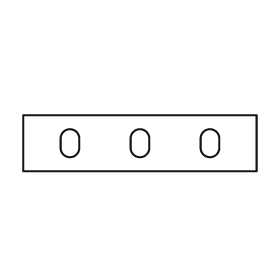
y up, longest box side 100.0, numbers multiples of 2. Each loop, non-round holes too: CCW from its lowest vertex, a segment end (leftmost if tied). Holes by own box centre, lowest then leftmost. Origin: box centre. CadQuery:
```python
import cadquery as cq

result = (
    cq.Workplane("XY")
    .moveTo(-50.0, -12.0)
    .lineTo(50.0, -12.0)
    .lineTo(50.0, 12.0)
    .lineTo(-50.0, 12.0)
    .close()
    .moveTo(-34.0, -2.0)
    .threePointArc((-30.0, -6.0), (-26.0, -2.0))
    .lineTo(-26.0, 2.0)
    .threePointArc((-30.0, 6.0), (-34.0, 2.0))
    .close()
    .moveTo(-4.0, -2.0)
    .threePointArc((0.0, -6.0), (4.0, -2.0))
    .lineTo(4.0, 2.0)
    .threePointArc((0.0, 6.0), (-4.0, 2.0))
    .close()
    .moveTo(26.0, -2.0)
    .threePointArc((30.0, -6.0), (34.0, -2.0))
    .lineTo(34.0, 2.0)
    .threePointArc((30.0, 6.0), (26.0, 2.0))
    .close()
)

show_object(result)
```